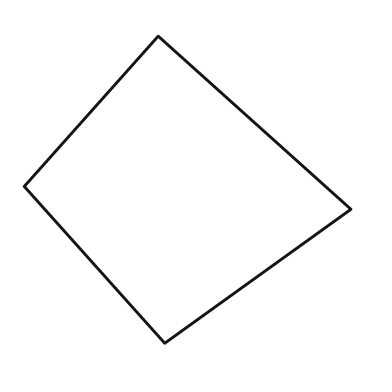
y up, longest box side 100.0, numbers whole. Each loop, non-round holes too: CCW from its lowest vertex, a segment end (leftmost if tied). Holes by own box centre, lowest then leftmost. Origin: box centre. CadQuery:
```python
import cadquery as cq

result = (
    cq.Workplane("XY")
    .moveTo(-7.0, -47.0)
    .lineTo(50.0, -6.0)
    .lineTo(-9.0, 47.0)
    .lineTo(-50.0, 1.0)
    .close()
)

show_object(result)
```